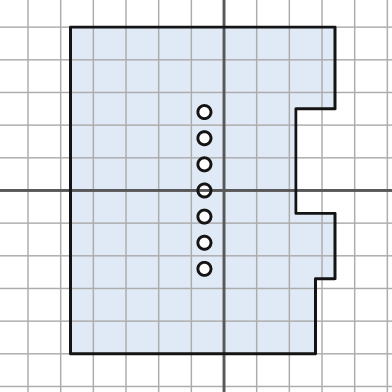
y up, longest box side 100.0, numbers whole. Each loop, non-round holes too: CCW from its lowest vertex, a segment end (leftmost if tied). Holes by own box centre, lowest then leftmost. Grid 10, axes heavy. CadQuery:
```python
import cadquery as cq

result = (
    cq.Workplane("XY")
    .moveTo(-47.0, -50.0)
    .lineTo(28.0, -50.0)
    .lineTo(28.0, -27.0)
    .lineTo(34.0, -27.0)
    .lineTo(34.0, -7.0)
    .lineTo(22.0, -7.0)
    .lineTo(22.0, 25.0)
    .lineTo(34.0, 25.0)
    .lineTo(34.0, 50.0)
    .lineTo(-47.0, 50.0)
    .close()
    .moveTo(-6.0, -24.0)
    .circle(2.0)
    .moveTo(-6.0, -16.0)
    .circle(2.0)
    .moveTo(-6.0, -8.0)
    .circle(2.0)
    .moveTo(-6.0, 0.0)
    .circle(2.0)
    .moveTo(-6.0, 8.0)
    .circle(2.0)
    .moveTo(-6.0, 16.0)
    .circle(2.0)
    .moveTo(-6.0, 24.0)
    .circle(2.0)
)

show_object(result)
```